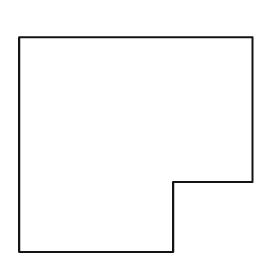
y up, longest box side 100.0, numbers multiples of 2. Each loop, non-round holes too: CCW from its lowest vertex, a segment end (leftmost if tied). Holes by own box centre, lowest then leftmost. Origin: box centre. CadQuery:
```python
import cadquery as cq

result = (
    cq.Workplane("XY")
    .moveTo(-50.0, -46.0)
    .lineTo(16.0, -46.0)
    .lineTo(16.0, -16.0)
    .lineTo(50.0, -16.0)
    .lineTo(50.0, 46.0)
    .lineTo(-50.0, 46.0)
    .close()
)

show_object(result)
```